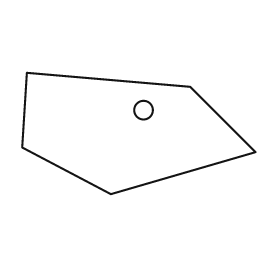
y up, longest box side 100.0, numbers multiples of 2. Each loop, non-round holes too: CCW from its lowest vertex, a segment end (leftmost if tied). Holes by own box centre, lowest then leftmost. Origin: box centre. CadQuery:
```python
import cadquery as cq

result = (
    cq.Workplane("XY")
    .moveTo(-12.0, -26.0)
    .lineTo(50.0, -8.0)
    .lineTo(22.0, 20.0)
    .lineTo(-48.0, 26.0)
    .lineTo(-50.0, -6.0)
    .close()
    .moveTo(2.0, 10.0)
    .circle(4.0)
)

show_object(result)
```